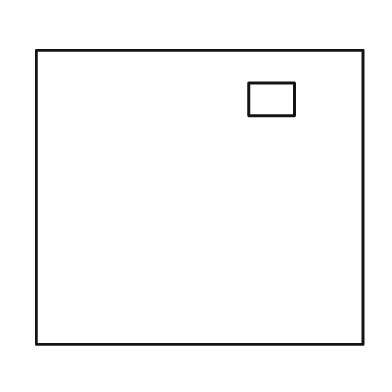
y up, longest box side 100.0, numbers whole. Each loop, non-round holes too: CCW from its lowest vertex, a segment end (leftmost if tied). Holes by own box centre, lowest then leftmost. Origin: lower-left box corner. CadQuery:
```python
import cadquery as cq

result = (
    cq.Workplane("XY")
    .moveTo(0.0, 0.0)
    .lineTo(100.0, 0.0)
    .lineTo(100.0, 90.0)
    .lineTo(0.0, 90.0)
    .close()
    .moveTo(65.0, 70.0)
    .lineTo(79.0, 70.0)
    .lineTo(79.0, 80.0)
    .lineTo(65.0, 80.0)
    .close()
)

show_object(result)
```